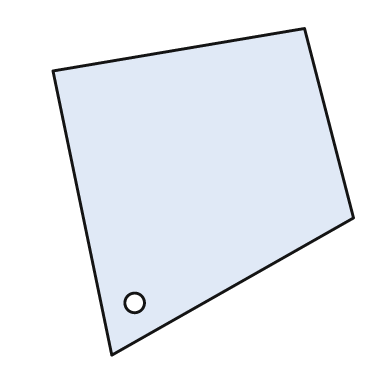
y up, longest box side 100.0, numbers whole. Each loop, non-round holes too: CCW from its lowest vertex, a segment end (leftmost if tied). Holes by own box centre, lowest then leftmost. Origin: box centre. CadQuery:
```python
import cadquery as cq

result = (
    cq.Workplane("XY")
    .moveTo(-28.0, -50.0)
    .lineTo(46.0, -8.0)
    .lineTo(31.0, 50.0)
    .lineTo(-46.0, 37.0)
    .close()
    .moveTo(-21.0, -34.0)
    .circle(3.0)
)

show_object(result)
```